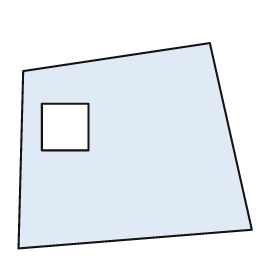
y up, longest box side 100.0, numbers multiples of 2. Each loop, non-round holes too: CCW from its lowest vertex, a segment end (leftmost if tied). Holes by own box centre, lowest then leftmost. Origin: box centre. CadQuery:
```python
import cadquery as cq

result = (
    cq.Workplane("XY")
    .moveTo(-50.0, -44.0)
    .lineTo(50.0, -36.0)
    .lineTo(32.0, 44.0)
    .lineTo(-48.0, 32.0)
    .close()
    .moveTo(-40.0, -2.0)
    .lineTo(-20.0, -2.0)
    .lineTo(-20.0, 18.0)
    .lineTo(-40.0, 18.0)
    .close()
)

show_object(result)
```